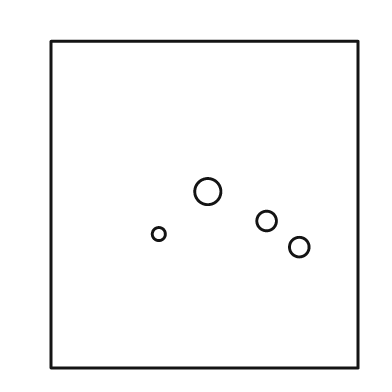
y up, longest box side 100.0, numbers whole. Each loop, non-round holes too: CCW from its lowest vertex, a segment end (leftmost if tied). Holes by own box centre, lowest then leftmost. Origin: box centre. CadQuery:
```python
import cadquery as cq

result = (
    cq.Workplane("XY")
    .moveTo(-47.0, -50.0)
    .lineTo(47.0, -50.0)
    .lineTo(47.0, 50.0)
    .lineTo(-47.0, 50.0)
    .close()
    .moveTo(29.0, -13.0)
    .circle(3.0)
    .moveTo(-14.0, -9.0)
    .circle(2.0)
    .moveTo(19.0, -5.0)
    .circle(3.0)
    .moveTo(1.0, 4.0)
    .circle(4.0)
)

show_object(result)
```